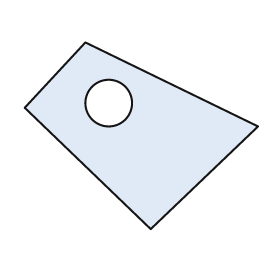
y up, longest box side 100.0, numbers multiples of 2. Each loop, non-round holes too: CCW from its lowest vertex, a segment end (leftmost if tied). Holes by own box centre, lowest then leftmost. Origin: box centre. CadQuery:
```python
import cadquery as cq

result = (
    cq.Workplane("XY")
    .moveTo(4.0, -40.0)
    .lineTo(50.0, 4.0)
    .lineTo(-24.0, 40.0)
    .lineTo(-50.0, 12.0)
    .close()
    .moveTo(-14.0, 14.0)
    .circle(10.0)
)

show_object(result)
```